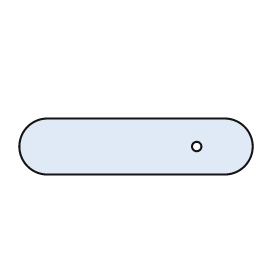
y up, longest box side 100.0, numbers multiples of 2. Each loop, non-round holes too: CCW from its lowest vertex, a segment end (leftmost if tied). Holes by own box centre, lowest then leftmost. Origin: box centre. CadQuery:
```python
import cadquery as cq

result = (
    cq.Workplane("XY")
    .moveTo(-38.0, -12.0)
    .lineTo(38.0, -12.0)
    .threePointArc((50.0, 0.0), (38.0, 12.0))
    .lineTo(-38.0, 12.0)
    .threePointArc((-50.0, 0.0), (-38.0, -12.0))
    .close()
    .moveTo(26.0, 0.0)
    .circle(2.0)
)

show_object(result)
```